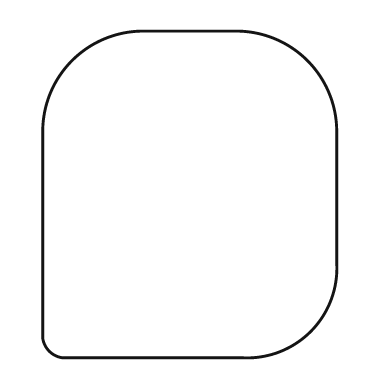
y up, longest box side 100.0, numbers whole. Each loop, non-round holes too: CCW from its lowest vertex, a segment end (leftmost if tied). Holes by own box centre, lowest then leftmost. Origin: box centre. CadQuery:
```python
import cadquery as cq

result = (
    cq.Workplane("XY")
    .moveTo(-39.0, -50.0)
    .lineTo(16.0, -50.0)
    .threePointArc((37.0, -42.0), (45.0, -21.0))
    .lineTo(45.0, 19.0)
    .threePointArc((36.0, 41.0), (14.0, 50.0))
    .lineTo(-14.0, 50.0)
    .threePointArc((-36.0, 41.0), (-45.0, 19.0))
    .lineTo(-45.0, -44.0)
    .threePointArc((-43.0, -48.0), (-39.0, -50.0))
    .close()
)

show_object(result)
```